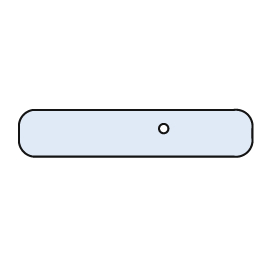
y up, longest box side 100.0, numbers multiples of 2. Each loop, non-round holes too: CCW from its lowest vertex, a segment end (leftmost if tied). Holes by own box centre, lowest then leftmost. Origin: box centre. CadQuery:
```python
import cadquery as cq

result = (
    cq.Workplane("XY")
    .moveTo(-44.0, -10.0)
    .lineTo(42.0, -10.0)
    .threePointArc((48.0, -8.0), (50.0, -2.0))
    .lineTo(50.0, 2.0)
    .threePointArc((48.0, 8.0), (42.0, 10.0))
    .lineTo(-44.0, 10.0)
    .threePointArc((-48.0, 8.0), (-50.0, 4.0))
    .lineTo(-50.0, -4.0)
    .threePointArc((-48.0, -8.0), (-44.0, -10.0))
    .close()
    .moveTo(12.0, 2.0)
    .circle(2.0)
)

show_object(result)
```